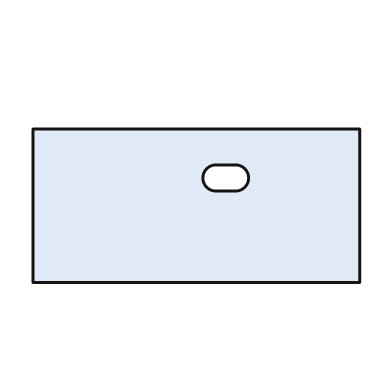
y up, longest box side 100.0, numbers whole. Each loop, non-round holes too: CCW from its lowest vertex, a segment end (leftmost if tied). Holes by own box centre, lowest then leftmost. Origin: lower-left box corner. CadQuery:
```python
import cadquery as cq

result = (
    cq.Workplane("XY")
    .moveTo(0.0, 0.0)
    .lineTo(100.0, 0.0)
    .lineTo(100.0, 47.0)
    .lineTo(0.0, 47.0)
    .close()
    .moveTo(56.0, 28.0)
    .lineTo(62.0, 28.0)
    .threePointArc((66.0, 32.0), (62.0, 36.0))
    .lineTo(56.0, 36.0)
    .threePointArc((52.0, 32.0), (56.0, 28.0))
    .close()
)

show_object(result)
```